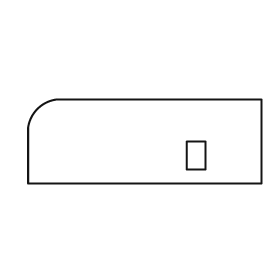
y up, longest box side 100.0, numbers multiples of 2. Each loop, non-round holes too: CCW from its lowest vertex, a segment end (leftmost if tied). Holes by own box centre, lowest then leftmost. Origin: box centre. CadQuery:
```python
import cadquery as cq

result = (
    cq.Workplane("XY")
    .moveTo(-50.0, -18.0)
    .lineTo(50.0, -18.0)
    .lineTo(50.0, 18.0)
    .lineTo(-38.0, 18.0)
    .threePointArc((-46.0, 14.0), (-50.0, 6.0))
    .close()
    .moveTo(18.0, -12.0)
    .lineTo(26.0, -12.0)
    .lineTo(26.0, 0.0)
    .lineTo(18.0, 0.0)
    .close()
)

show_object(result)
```